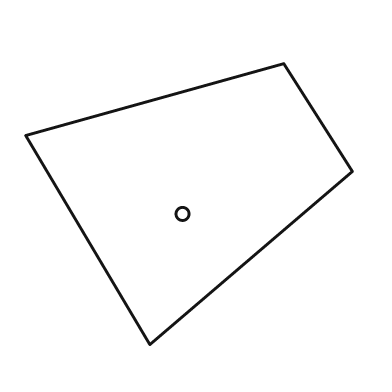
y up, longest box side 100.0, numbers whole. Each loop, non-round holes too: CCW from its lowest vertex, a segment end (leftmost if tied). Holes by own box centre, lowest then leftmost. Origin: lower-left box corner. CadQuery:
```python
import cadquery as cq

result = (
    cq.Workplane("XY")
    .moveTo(38.0, 0.0)
    .lineTo(100.0, 53.0)
    .lineTo(79.0, 86.0)
    .lineTo(0.0, 64.0)
    .close()
    .moveTo(48.0, 40.0)
    .circle(2.0)
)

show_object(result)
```